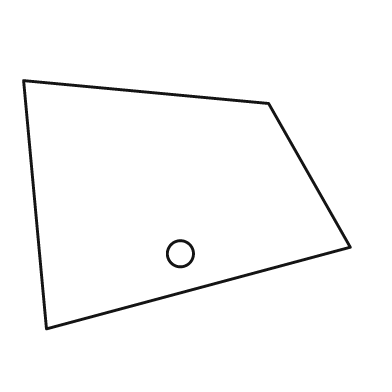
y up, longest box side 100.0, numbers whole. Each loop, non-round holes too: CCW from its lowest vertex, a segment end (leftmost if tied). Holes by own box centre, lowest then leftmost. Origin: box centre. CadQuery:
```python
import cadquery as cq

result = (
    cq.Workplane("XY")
    .moveTo(-43.0, -38.0)
    .lineTo(50.0, -13.0)
    .lineTo(25.0, 31.0)
    .lineTo(-50.0, 38.0)
    .close()
    .moveTo(-2.0, -15.0)
    .circle(4.0)
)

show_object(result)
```